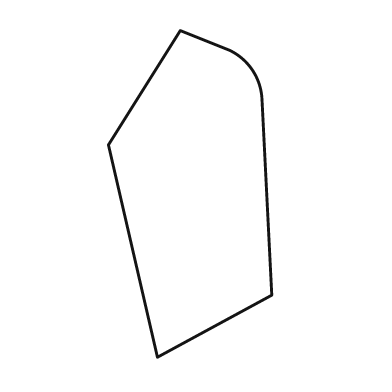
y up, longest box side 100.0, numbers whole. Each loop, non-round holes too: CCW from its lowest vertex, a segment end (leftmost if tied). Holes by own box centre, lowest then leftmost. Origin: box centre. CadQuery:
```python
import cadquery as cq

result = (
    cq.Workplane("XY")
    .moveTo(-10.0, -50.0)
    .lineTo(25.0, -31.0)
    .lineTo(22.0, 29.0)
    .threePointArc((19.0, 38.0), (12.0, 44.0))
    .lineTo(-3.0, 50.0)
    .lineTo(-25.0, 15.0)
    .close()
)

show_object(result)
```